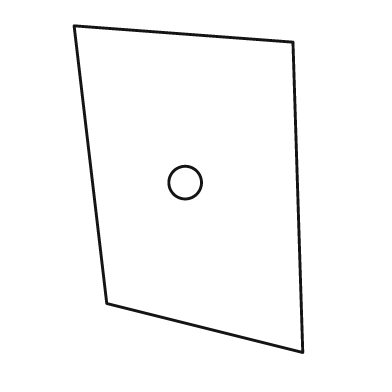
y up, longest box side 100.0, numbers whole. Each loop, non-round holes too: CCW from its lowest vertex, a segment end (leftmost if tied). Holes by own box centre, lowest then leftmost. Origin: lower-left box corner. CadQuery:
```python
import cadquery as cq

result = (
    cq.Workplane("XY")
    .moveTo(70.0, 0.0)
    .lineTo(67.0, 95.0)
    .lineTo(0.0, 100.0)
    .lineTo(10.0, 15.0)
    .close()
    .moveTo(34.0, 52.0)
    .circle(5.0)
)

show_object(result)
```